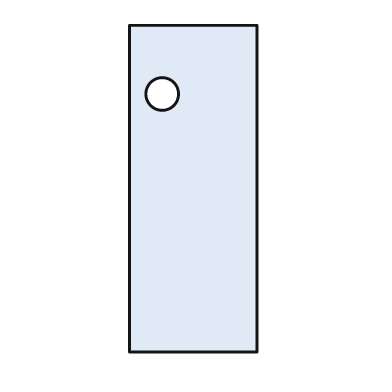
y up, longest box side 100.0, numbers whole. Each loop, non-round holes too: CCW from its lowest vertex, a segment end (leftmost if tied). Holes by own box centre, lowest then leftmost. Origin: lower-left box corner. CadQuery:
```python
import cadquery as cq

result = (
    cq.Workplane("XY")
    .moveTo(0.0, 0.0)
    .lineTo(39.0, 0.0)
    .lineTo(39.0, 100.0)
    .lineTo(0.0, 100.0)
    .close()
    .moveTo(10.0, 79.0)
    .circle(5.0)
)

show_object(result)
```